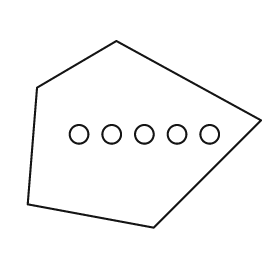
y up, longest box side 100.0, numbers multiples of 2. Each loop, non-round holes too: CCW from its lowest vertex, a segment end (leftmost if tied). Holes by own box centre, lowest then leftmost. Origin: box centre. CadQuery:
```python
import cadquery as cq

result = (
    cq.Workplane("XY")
    .moveTo(4.0, -40.0)
    .lineTo(50.0, 6.0)
    .lineTo(-12.0, 40.0)
    .lineTo(-46.0, 20.0)
    .lineTo(-50.0, -30.0)
    .close()
    .moveTo(-28.0, 0.0)
    .circle(4.0)
    .moveTo(-14.0, 0.0)
    .circle(4.0)
    .moveTo(0.0, 0.0)
    .circle(4.0)
    .moveTo(14.0, 0.0)
    .circle(4.0)
    .moveTo(28.0, 0.0)
    .circle(4.0)
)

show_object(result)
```